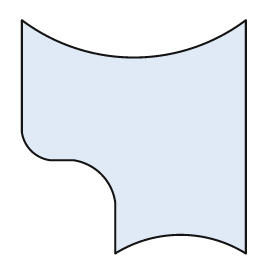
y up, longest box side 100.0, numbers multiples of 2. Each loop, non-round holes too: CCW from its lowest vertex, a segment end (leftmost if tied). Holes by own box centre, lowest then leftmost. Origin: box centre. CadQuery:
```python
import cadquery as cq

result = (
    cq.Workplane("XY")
    .moveTo(-8.0, -50.0)
    .threePointArc((20.0, -42.0), (48.0, -50.0))
    .lineTo(48.0, 50.0)
    .threePointArc((0.0, 34.0), (-48.0, 50.0))
    .lineTo(-48.0, 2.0)
    .threePointArc((-44.0, -6.0), (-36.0, -10.0))
    .lineTo(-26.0, -10.0)
    .threePointArc((-14.0, -16.0), (-8.0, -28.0))
    .close()
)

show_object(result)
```